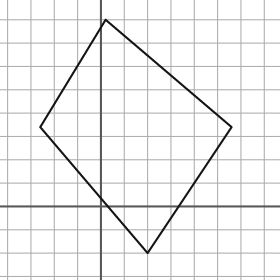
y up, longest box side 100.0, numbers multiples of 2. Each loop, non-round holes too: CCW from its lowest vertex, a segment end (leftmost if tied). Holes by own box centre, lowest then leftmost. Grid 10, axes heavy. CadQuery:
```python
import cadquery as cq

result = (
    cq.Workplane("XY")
    .moveTo(20.0, -20.0)
    .lineTo(56.0, 34.0)
    .lineTo(2.0, 80.0)
    .lineTo(-26.0, 34.0)
    .close()
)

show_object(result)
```